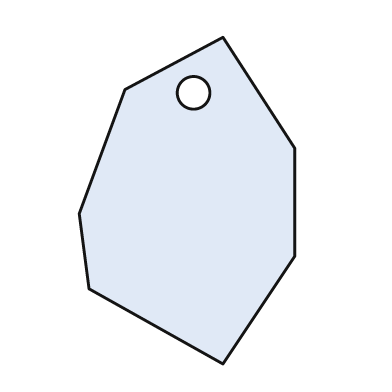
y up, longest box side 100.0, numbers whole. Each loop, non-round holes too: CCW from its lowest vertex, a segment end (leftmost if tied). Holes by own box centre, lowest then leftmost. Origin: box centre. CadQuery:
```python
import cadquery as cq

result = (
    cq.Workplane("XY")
    .moveTo(11.0, -50.0)
    .lineTo(33.0, -17.0)
    .lineTo(33.0, 16.0)
    .lineTo(11.0, 50.0)
    .lineTo(-19.0, 34.0)
    .lineTo(-33.0, -4.0)
    .lineTo(-30.0, -27.0)
    .close()
    .moveTo(2.0, 33.0)
    .circle(5.0)
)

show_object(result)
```